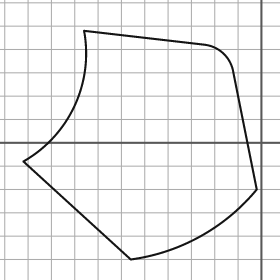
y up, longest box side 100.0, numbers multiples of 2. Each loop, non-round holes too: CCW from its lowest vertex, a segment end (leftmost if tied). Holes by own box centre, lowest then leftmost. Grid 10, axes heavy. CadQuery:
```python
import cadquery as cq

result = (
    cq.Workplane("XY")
    .moveTo(-56.0, -50.0)
    .threePointArc((-26.0, -40.0), (-2.0, -20.0))
    .lineTo(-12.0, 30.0)
    .threePointArc((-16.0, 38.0), (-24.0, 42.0))
    .lineTo(-76.0, 48.0)
    .threePointArc((-80.0, 16.0), (-102.0, -8.0))
    .close()
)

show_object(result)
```